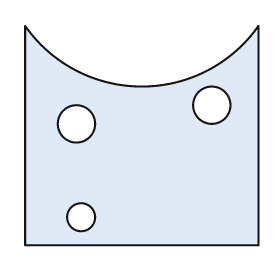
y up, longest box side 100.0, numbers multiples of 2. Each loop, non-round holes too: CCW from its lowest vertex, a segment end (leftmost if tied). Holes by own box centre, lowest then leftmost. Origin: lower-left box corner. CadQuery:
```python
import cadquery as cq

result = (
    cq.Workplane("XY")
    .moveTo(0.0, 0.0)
    .lineTo(100.0, 0.0)
    .lineTo(100.0, 94.0)
    .threePointArc((50.0, 68.0), (0.0, 94.0))
    .close()
    .moveTo(24.0, 12.0)
    .circle(6.0)
    .moveTo(22.0, 52.0)
    .circle(8.0)
    .moveTo(80.0, 60.0)
    .circle(8.0)
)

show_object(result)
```